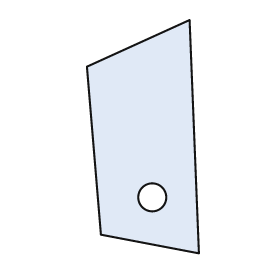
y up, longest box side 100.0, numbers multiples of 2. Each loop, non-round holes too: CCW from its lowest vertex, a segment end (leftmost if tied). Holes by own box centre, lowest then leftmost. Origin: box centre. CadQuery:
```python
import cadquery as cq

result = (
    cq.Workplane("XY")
    .moveTo(24.0, -50.0)
    .lineTo(20.0, 50.0)
    .lineTo(-24.0, 30.0)
    .lineTo(-18.0, -42.0)
    .close()
    .moveTo(4.0, -26.0)
    .circle(6.0)
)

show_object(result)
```